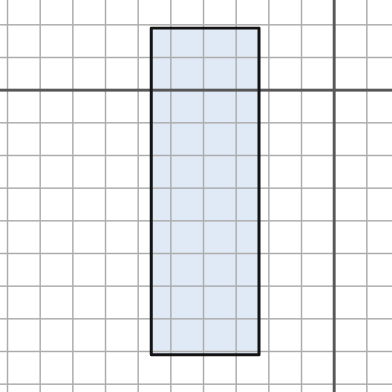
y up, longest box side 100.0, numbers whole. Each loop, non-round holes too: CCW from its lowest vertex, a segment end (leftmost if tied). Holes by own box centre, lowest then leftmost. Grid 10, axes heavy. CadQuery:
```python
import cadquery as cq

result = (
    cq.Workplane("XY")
    .moveTo(-56.0, -81.0)
    .lineTo(-23.0, -81.0)
    .lineTo(-23.0, 19.0)
    .lineTo(-56.0, 19.0)
    .close()
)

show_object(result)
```